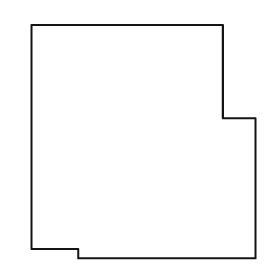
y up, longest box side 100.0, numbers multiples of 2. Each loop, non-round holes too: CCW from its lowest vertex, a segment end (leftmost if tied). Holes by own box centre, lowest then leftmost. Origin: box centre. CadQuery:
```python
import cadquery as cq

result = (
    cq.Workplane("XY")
    .moveTo(-28.0, -50.0)
    .lineTo(48.0, -50.0)
    .lineTo(48.0, 10.0)
    .lineTo(34.0, 10.0)
    .lineTo(34.0, 50.0)
    .lineTo(-48.0, 50.0)
    .lineTo(-48.0, -46.0)
    .lineTo(-28.0, -46.0)
    .close()
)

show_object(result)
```